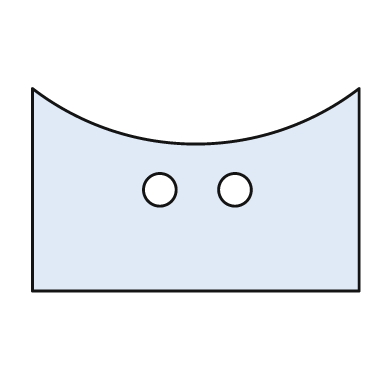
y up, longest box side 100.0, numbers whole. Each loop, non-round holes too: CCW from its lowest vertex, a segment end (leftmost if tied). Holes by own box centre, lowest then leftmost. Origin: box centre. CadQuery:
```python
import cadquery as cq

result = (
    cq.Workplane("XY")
    .moveTo(-50.0, -31.0)
    .lineTo(50.0, -31.0)
    .lineTo(50.0, 31.0)
    .threePointArc((0.0, 14.0), (-50.0, 31.0))
    .close()
    .moveTo(-11.0, 0.0)
    .circle(5.0)
    .moveTo(12.0, 0.0)
    .circle(5.0)
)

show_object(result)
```